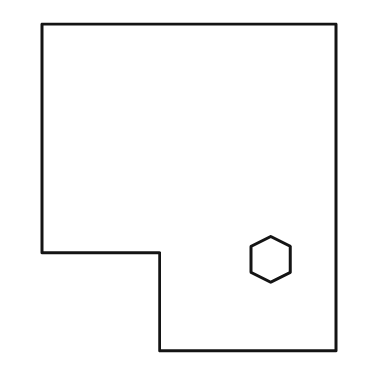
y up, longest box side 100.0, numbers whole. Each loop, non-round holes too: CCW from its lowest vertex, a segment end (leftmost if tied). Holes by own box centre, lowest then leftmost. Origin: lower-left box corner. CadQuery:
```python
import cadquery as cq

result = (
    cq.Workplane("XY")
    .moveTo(36.0, 0.0)
    .lineTo(90.0, 0.0)
    .lineTo(90.0, 100.0)
    .lineTo(0.0, 100.0)
    .lineTo(0.0, 30.0)
    .lineTo(36.0, 30.0)
    .close()
    .moveTo(70.0, 21.0)
    .lineTo(76.0, 24.0)
    .lineTo(76.0, 32.0)
    .lineTo(70.0, 35.0)
    .lineTo(64.0, 32.0)
    .lineTo(64.0, 24.0)
    .close()
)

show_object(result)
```